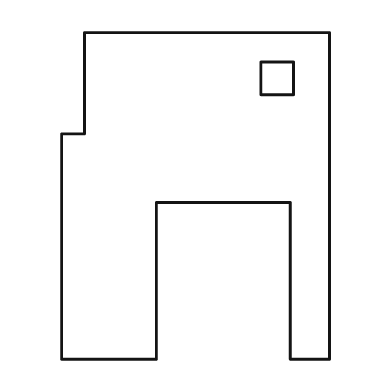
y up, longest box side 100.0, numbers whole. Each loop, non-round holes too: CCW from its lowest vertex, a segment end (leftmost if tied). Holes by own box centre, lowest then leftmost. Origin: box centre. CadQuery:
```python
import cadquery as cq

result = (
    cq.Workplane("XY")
    .moveTo(-41.0, -50.0)
    .lineTo(-12.0, -50.0)
    .lineTo(-12.0, -2.0)
    .lineTo(29.0, -2.0)
    .lineTo(29.0, -50.0)
    .lineTo(41.0, -50.0)
    .lineTo(41.0, 50.0)
    .lineTo(-34.0, 50.0)
    .lineTo(-34.0, 19.0)
    .lineTo(-41.0, 19.0)
    .close()
    .moveTo(20.0, 31.0)
    .lineTo(30.0, 31.0)
    .lineTo(30.0, 41.0)
    .lineTo(20.0, 41.0)
    .close()
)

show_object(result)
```